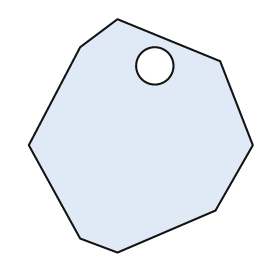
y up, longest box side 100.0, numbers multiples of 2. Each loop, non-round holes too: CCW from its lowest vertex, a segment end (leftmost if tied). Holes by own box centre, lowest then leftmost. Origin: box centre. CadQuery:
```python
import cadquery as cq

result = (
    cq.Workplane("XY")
    .moveTo(-10.0, -50.0)
    .lineTo(32.0, -32.0)
    .lineTo(48.0, -4.0)
    .lineTo(34.0, 32.0)
    .lineTo(-10.0, 50.0)
    .lineTo(-26.0, 38.0)
    .lineTo(-48.0, -4.0)
    .lineTo(-26.0, -44.0)
    .close()
    .moveTo(6.0, 30.0)
    .circle(8.0)
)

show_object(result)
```